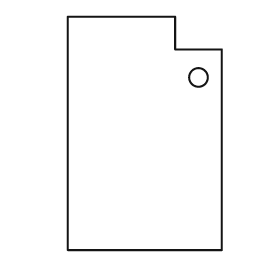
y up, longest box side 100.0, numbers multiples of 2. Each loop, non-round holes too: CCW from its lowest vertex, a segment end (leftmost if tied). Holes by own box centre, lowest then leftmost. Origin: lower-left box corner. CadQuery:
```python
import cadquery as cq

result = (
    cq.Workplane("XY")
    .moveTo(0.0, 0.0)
    .lineTo(66.0, 0.0)
    .lineTo(66.0, 86.0)
    .lineTo(46.0, 86.0)
    .lineTo(46.0, 100.0)
    .lineTo(0.0, 100.0)
    .close()
    .moveTo(56.0, 74.0)
    .circle(4.0)
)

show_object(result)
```